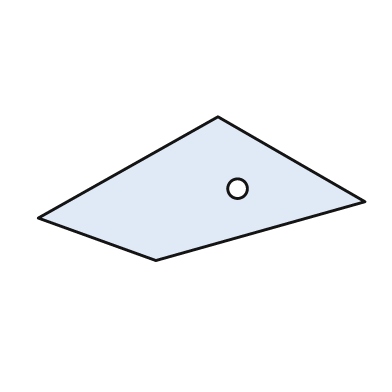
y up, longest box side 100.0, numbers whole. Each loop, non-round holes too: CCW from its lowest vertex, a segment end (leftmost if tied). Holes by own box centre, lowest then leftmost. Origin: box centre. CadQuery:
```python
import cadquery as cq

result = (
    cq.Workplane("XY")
    .moveTo(-14.0, -22.0)
    .lineTo(50.0, -4.0)
    .lineTo(5.0, 22.0)
    .lineTo(-50.0, -9.0)
    .close()
    .moveTo(11.0, 0.0)
    .circle(3.0)
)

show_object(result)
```